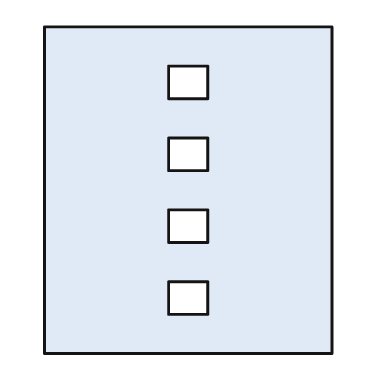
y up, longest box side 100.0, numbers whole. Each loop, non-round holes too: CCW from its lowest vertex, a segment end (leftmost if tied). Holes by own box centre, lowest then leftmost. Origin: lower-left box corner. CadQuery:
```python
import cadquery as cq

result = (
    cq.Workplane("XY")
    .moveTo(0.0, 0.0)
    .lineTo(88.0, 0.0)
    .lineTo(88.0, 100.0)
    .lineTo(0.0, 100.0)
    .close()
    .moveTo(38.0, 12.0)
    .lineTo(50.0, 12.0)
    .lineTo(50.0, 22.0)
    .lineTo(38.0, 22.0)
    .close()
    .moveTo(38.0, 34.0)
    .lineTo(50.0, 34.0)
    .lineTo(50.0, 44.0)
    .lineTo(38.0, 44.0)
    .close()
    .moveTo(38.0, 56.0)
    .lineTo(50.0, 56.0)
    .lineTo(50.0, 66.0)
    .lineTo(38.0, 66.0)
    .close()
    .moveTo(38.0, 78.0)
    .lineTo(50.0, 78.0)
    .lineTo(50.0, 88.0)
    .lineTo(38.0, 88.0)
    .close()
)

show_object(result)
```